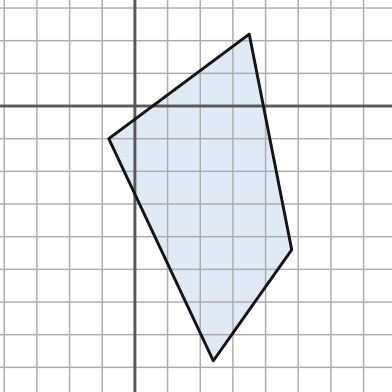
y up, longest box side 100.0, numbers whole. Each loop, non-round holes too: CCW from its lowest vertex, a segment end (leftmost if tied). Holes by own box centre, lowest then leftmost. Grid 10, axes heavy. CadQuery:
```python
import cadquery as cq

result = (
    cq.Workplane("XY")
    .moveTo(24.0, -78.0)
    .lineTo(48.0, -44.0)
    .lineTo(35.0, 22.0)
    .lineTo(-8.0, -10.0)
    .close()
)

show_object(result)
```